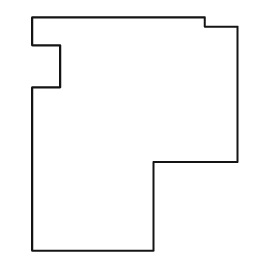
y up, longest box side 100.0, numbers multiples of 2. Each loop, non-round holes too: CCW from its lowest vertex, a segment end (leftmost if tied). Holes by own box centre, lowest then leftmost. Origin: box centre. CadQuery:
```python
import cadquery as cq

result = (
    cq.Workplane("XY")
    .moveTo(-44.0, -50.0)
    .lineTo(8.0, -50.0)
    .lineTo(8.0, -12.0)
    .lineTo(44.0, -12.0)
    .lineTo(44.0, 46.0)
    .lineTo(30.0, 46.0)
    .lineTo(30.0, 50.0)
    .lineTo(-44.0, 50.0)
    .lineTo(-44.0, 38.0)
    .lineTo(-32.0, 38.0)
    .lineTo(-32.0, 20.0)
    .lineTo(-44.0, 20.0)
    .close()
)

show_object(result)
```